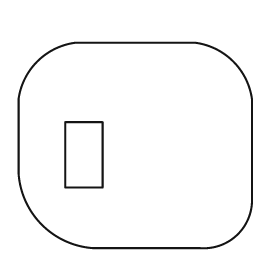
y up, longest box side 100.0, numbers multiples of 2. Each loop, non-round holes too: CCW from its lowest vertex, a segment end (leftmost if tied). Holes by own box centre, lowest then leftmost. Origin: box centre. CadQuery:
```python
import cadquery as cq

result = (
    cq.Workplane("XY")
    .moveTo(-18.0, -44.0)
    .lineTo(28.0, -44.0)
    .threePointArc((44.0, -38.0), (50.0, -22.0))
    .lineTo(50.0, 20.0)
    .threePointArc((42.0, 36.0), (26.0, 44.0))
    .lineTo(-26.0, 44.0)
    .threePointArc((-42.0, 36.0), (-50.0, 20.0))
    .lineTo(-50.0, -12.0)
    .threePointArc((-40.0, -34.0), (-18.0, -44.0))
    .close()
    .moveTo(-30.0, -18.0)
    .lineTo(-14.0, -18.0)
    .lineTo(-14.0, 10.0)
    .lineTo(-30.0, 10.0)
    .close()
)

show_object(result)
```